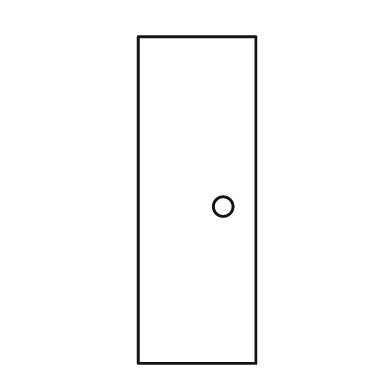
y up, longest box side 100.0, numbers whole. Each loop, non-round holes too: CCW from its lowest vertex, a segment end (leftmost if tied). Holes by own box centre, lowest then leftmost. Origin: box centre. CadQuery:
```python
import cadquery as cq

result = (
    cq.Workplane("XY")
    .moveTo(-18.0, -50.0)
    .lineTo(18.0, -50.0)
    .lineTo(18.0, 50.0)
    .lineTo(-18.0, 50.0)
    .close()
    .moveTo(8.0, -2.0)
    .circle(3.0)
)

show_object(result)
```